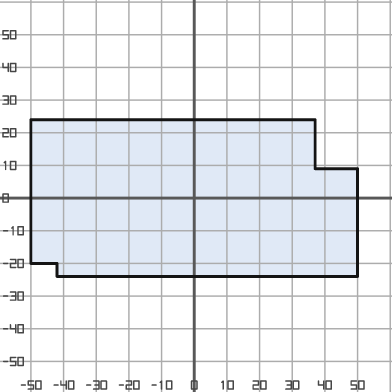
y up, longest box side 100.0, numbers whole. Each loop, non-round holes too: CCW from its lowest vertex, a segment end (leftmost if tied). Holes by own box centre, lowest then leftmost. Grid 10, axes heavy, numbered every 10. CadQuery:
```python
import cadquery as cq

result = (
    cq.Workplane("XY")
    .moveTo(-42.0, -24.0)
    .lineTo(50.0, -24.0)
    .lineTo(50.0, 9.0)
    .lineTo(37.0, 9.0)
    .lineTo(37.0, 24.0)
    .lineTo(-50.0, 24.0)
    .lineTo(-50.0, -20.0)
    .lineTo(-42.0, -20.0)
    .close()
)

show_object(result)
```